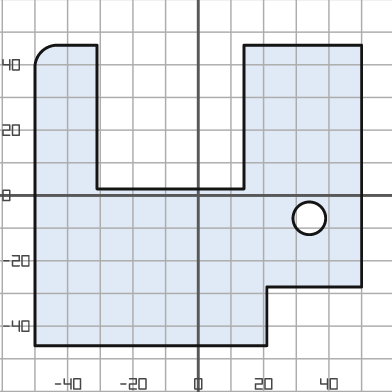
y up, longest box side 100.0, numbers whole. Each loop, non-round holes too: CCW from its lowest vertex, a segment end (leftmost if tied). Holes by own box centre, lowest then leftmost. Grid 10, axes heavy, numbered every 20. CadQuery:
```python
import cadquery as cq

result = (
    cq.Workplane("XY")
    .moveTo(-50.0, -46.0)
    .lineTo(21.0, -46.0)
    .lineTo(21.0, -28.0)
    .lineTo(50.0, -28.0)
    .lineTo(50.0, 46.0)
    .lineTo(14.0, 46.0)
    .lineTo(14.0, 2.0)
    .lineTo(-31.0, 2.0)
    .lineTo(-31.0, 46.0)
    .lineTo(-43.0, 46.0)
    .threePointArc((-48.0, 44.0), (-50.0, 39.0))
    .close()
    .moveTo(34.0, -7.0)
    .circle(5.0)
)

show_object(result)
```